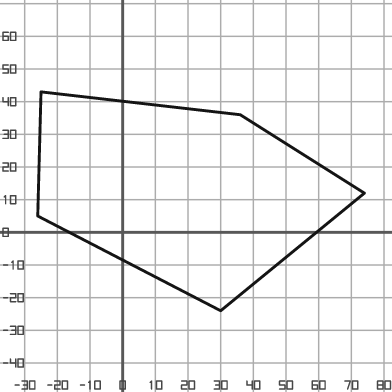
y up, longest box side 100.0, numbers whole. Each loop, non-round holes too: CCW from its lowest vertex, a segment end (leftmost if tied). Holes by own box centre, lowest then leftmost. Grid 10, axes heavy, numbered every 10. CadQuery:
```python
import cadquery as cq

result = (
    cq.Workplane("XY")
    .moveTo(30.0, -24.0)
    .lineTo(74.0, 12.0)
    .lineTo(36.0, 36.0)
    .lineTo(-25.0, 43.0)
    .lineTo(-26.0, 5.0)
    .close()
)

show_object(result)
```